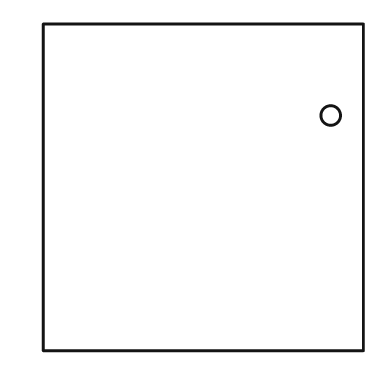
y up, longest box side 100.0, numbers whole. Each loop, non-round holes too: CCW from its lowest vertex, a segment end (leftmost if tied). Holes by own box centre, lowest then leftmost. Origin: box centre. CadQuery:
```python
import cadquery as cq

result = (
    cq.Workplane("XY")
    .moveTo(-49.0, -50.0)
    .lineTo(49.0, -50.0)
    .lineTo(49.0, 50.0)
    .lineTo(-49.0, 50.0)
    .close()
    .moveTo(39.0, 22.0)
    .circle(3.0)
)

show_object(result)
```